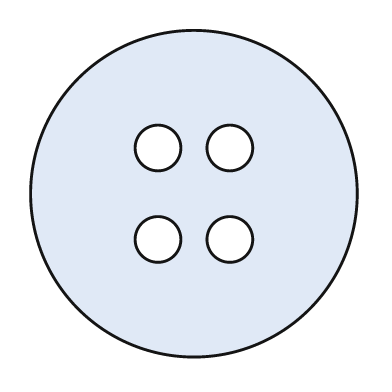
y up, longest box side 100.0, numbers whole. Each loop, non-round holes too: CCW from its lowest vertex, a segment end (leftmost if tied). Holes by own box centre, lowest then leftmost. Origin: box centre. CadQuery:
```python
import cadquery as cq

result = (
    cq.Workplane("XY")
    .moveTo(0.0, 0.0)
    .circle(50.0)
    .moveTo(-11.0, -14.0)
    .circle(7.0)
    .moveTo(11.0, -14.0)
    .circle(7.0)
    .moveTo(-11.0, 14.0)
    .circle(7.0)
    .moveTo(11.0, 14.0)
    .circle(7.0)
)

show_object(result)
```